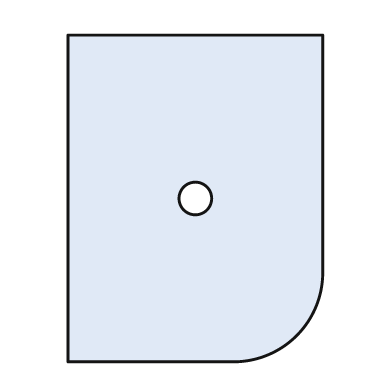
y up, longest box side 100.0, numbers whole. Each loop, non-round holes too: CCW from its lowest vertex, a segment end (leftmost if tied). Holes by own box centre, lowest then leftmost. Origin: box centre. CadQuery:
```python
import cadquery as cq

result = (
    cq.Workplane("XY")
    .moveTo(-39.0, -50.0)
    .lineTo(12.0, -50.0)
    .threePointArc((31.0, -42.0), (39.0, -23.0))
    .lineTo(39.0, 50.0)
    .lineTo(-39.0, 50.0)
    .close()
    .moveTo(0.0, 0.0)
    .circle(5.0)
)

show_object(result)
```